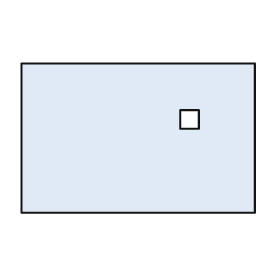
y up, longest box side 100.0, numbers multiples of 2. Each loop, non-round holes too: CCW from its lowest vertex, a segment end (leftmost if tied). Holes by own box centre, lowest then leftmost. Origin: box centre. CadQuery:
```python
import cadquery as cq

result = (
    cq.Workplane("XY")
    .moveTo(-50.0, -32.0)
    .lineTo(50.0, -32.0)
    .lineTo(50.0, 32.0)
    .lineTo(-50.0, 32.0)
    .close()
    .moveTo(18.0, 4.0)
    .lineTo(26.0, 4.0)
    .lineTo(26.0, 12.0)
    .lineTo(18.0, 12.0)
    .close()
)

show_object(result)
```